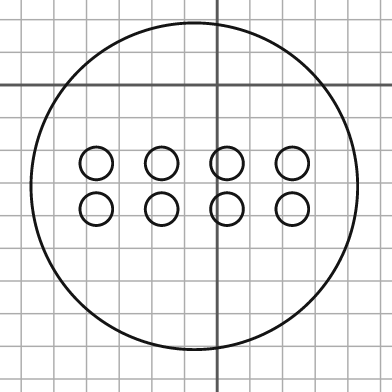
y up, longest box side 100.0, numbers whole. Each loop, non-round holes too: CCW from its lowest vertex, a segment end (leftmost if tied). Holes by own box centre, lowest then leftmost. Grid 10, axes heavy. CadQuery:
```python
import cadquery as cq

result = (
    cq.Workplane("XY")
    .moveTo(-7.0, -31.0)
    .circle(50.0)
    .moveTo(-37.0, -38.0)
    .circle(5.0)
    .moveTo(-17.0, -38.0)
    .circle(5.0)
    .moveTo(3.0, -38.0)
    .circle(5.0)
    .moveTo(23.0, -38.0)
    .circle(5.0)
    .moveTo(-37.0, -24.0)
    .circle(5.0)
    .moveTo(-17.0, -24.0)
    .circle(5.0)
    .moveTo(3.0, -24.0)
    .circle(5.0)
    .moveTo(23.0, -24.0)
    .circle(5.0)
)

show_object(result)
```